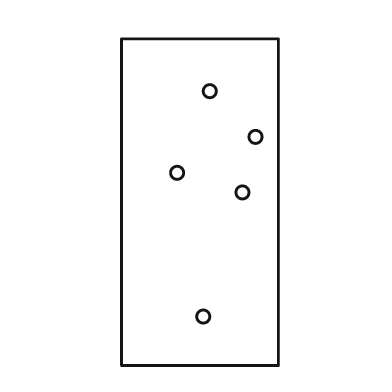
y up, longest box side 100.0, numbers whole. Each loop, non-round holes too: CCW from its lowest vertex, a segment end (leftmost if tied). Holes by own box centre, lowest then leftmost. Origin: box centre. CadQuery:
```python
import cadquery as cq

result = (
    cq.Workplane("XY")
    .moveTo(-24.0, -50.0)
    .lineTo(24.0, -50.0)
    .lineTo(24.0, 50.0)
    .lineTo(-24.0, 50.0)
    .close()
    .moveTo(1.0, -35.0)
    .circle(2.0)
    .moveTo(13.0, 3.0)
    .circle(2.0)
    .moveTo(-7.0, 9.0)
    .circle(2.0)
    .moveTo(17.0, 20.0)
    .circle(2.0)
    .moveTo(3.0, 34.0)
    .circle(2.0)
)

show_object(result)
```